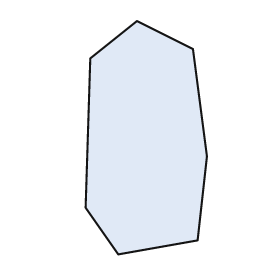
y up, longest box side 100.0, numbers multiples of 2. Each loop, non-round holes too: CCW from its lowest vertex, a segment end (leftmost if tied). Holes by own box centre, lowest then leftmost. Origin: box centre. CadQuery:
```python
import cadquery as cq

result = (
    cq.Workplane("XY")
    .moveTo(-12.0, -50.0)
    .lineTo(22.0, -44.0)
    .lineTo(26.0, -8.0)
    .lineTo(20.0, 38.0)
    .lineTo(-4.0, 50.0)
    .lineTo(-24.0, 34.0)
    .lineTo(-26.0, -30.0)
    .close()
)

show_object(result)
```